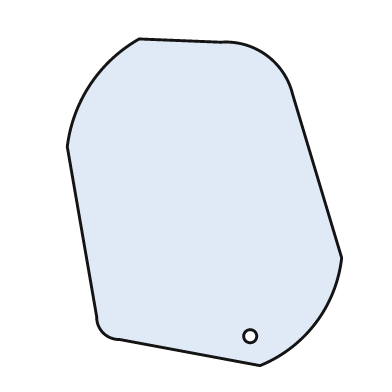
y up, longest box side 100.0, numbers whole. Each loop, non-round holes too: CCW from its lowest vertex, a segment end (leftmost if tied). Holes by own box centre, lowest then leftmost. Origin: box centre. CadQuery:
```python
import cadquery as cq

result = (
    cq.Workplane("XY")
    .moveTo(17.0, -50.0)
    .threePointArc((34.0, -37.0), (42.0, -17.0))
    .lineTo(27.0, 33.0)
    .threePointArc((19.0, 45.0), (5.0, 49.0))
    .lineTo(-20.0, 50.0)
    .threePointArc((-35.0, 36.0), (-42.0, 17.0))
    .lineTo(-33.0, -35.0)
    .threePointArc((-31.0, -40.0), (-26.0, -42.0))
    .close()
    .moveTo(14.0, -41.0)
    .circle(2.0)
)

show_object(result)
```